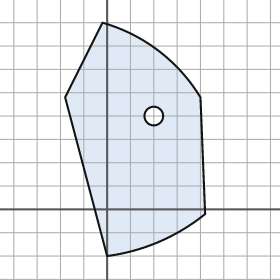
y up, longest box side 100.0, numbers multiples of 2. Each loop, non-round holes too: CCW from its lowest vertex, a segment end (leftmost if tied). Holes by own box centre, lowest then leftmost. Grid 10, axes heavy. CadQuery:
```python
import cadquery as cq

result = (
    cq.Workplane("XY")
    .moveTo(0.0, -20.0)
    .threePointArc((22.0, -14.0), (42.0, -2.0))
    .lineTo(40.0, 48.0)
    .threePointArc((22.0, 68.0), (-2.0, 80.0))
    .lineTo(-18.0, 48.0)
    .close()
    .moveTo(20.0, 40.0)
    .circle(4.0)
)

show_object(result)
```